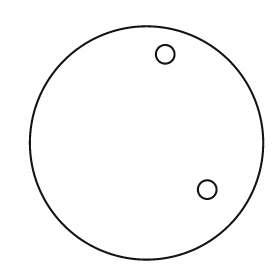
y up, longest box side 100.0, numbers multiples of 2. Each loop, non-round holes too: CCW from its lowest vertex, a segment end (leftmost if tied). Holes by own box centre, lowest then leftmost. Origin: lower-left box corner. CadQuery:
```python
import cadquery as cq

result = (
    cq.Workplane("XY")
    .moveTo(50.0, 50.0)
    .circle(50.0)
    .moveTo(76.0, 30.0)
    .circle(4.0)
    .moveTo(58.0, 88.0)
    .circle(4.0)
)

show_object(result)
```